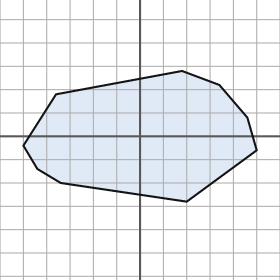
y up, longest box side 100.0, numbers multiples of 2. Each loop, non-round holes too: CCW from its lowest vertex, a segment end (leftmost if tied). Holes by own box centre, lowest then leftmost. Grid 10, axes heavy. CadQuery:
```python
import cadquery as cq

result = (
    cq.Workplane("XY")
    .moveTo(20.0, -28.0)
    .lineTo(50.0, -6.0)
    .lineTo(46.0, 8.0)
    .lineTo(34.0, 22.0)
    .lineTo(18.0, 28.0)
    .lineTo(-36.0, 18.0)
    .lineTo(-50.0, -4.0)
    .lineTo(-44.0, -14.0)
    .lineTo(-34.0, -20.0)
    .close()
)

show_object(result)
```